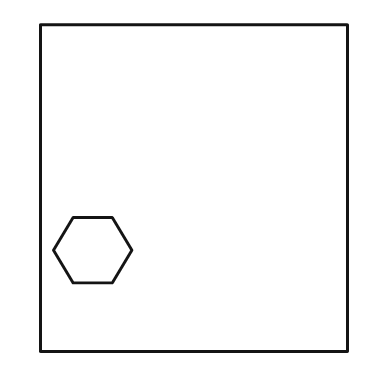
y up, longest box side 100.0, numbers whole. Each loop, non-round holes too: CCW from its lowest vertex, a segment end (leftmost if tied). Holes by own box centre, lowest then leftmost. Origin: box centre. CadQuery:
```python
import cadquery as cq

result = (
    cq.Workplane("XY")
    .moveTo(-47.0, -50.0)
    .lineTo(47.0, -50.0)
    .lineTo(47.0, 50.0)
    .lineTo(-47.0, 50.0)
    .close()
    .moveTo(-37.0, -29.0)
    .lineTo(-25.0, -29.0)
    .lineTo(-19.0, -19.0)
    .lineTo(-25.0, -9.0)
    .lineTo(-37.0, -9.0)
    .lineTo(-43.0, -19.0)
    .close()
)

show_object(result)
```